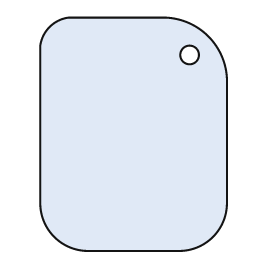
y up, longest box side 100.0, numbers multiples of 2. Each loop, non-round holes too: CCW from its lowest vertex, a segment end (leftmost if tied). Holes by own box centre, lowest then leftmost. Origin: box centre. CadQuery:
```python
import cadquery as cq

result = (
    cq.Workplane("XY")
    .moveTo(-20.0, -50.0)
    .lineTo(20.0, -50.0)
    .threePointArc((34.0, -44.0), (40.0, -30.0))
    .lineTo(40.0, 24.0)
    .threePointArc((32.0, 42.0), (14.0, 50.0))
    .lineTo(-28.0, 50.0)
    .threePointArc((-36.0, 46.0), (-40.0, 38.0))
    .lineTo(-40.0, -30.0)
    .threePointArc((-34.0, -44.0), (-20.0, -50.0))
    .close()
    .moveTo(24.0, 34.0)
    .circle(4.0)
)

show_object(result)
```